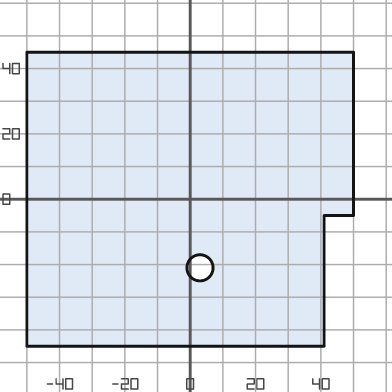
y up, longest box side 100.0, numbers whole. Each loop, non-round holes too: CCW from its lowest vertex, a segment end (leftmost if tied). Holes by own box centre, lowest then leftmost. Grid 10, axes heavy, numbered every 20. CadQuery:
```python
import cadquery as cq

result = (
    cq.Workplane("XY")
    .moveTo(-50.0, -45.0)
    .lineTo(41.0, -45.0)
    .lineTo(41.0, -5.0)
    .lineTo(50.0, -5.0)
    .lineTo(50.0, 45.0)
    .lineTo(-50.0, 45.0)
    .close()
    .moveTo(3.0, -21.0)
    .circle(4.0)
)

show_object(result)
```